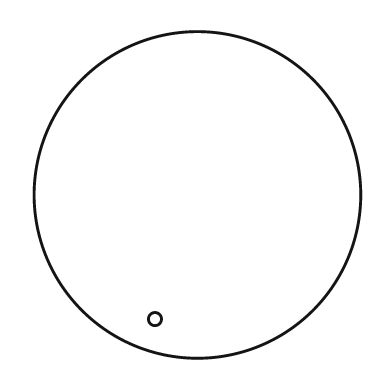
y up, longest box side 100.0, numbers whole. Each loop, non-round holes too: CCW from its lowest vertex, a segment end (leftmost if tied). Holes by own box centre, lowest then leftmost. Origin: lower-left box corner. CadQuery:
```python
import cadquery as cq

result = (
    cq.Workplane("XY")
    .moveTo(50.0, 50.0)
    .circle(50.0)
    .moveTo(37.0, 12.0)
    .circle(2.0)
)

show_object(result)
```